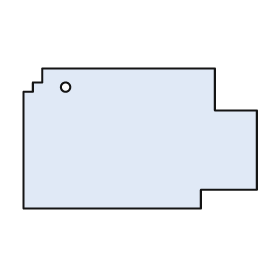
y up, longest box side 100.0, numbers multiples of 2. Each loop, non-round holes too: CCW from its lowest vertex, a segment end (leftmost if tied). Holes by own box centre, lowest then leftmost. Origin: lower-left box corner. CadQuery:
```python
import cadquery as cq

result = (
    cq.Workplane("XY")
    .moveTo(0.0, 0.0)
    .lineTo(76.0, 0.0)
    .lineTo(76.0, 8.0)
    .lineTo(100.0, 8.0)
    .lineTo(100.0, 42.0)
    .lineTo(82.0, 42.0)
    .lineTo(82.0, 60.0)
    .lineTo(8.0, 60.0)
    .lineTo(8.0, 54.0)
    .lineTo(4.0, 54.0)
    .lineTo(4.0, 50.0)
    .lineTo(0.0, 50.0)
    .close()
    .moveTo(18.0, 52.0)
    .circle(2.0)
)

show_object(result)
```